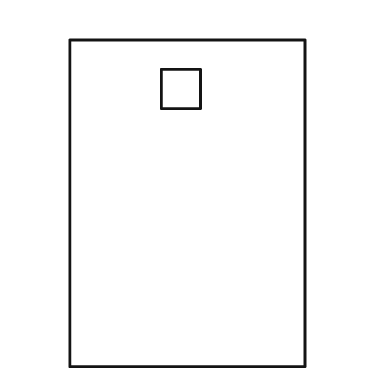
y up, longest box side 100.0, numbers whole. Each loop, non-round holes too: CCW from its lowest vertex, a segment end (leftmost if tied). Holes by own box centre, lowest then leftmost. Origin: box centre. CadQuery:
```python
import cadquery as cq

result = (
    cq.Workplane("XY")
    .moveTo(-36.0, -50.0)
    .lineTo(36.0, -50.0)
    .lineTo(36.0, 50.0)
    .lineTo(-36.0, 50.0)
    .close()
    .moveTo(-8.0, 29.0)
    .lineTo(4.0, 29.0)
    .lineTo(4.0, 41.0)
    .lineTo(-8.0, 41.0)
    .close()
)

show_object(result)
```